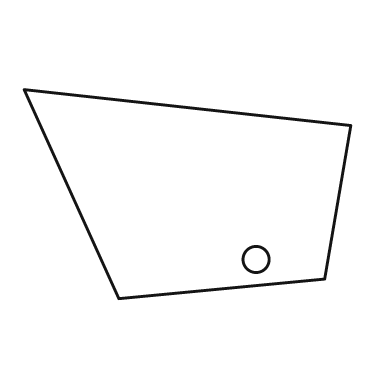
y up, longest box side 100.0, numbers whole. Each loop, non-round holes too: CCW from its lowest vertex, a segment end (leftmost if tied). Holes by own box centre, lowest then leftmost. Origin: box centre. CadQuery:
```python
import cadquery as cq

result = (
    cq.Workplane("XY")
    .moveTo(-21.0, -32.0)
    .lineTo(42.0, -26.0)
    .lineTo(50.0, 21.0)
    .lineTo(-50.0, 32.0)
    .close()
    .moveTo(21.0, -20.0)
    .circle(4.0)
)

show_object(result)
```